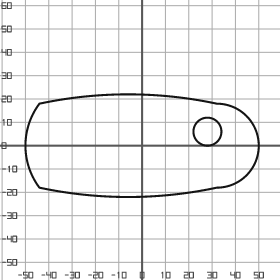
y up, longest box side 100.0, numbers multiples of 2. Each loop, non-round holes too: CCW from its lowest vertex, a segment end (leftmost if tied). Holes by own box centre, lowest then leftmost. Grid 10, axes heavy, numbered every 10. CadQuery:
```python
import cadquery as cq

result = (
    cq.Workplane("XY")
    .moveTo(-44.0, -18.0)
    .threePointArc((-6.0, -22.0), (32.0, -18.0))
    .threePointArc((50.0, 0.0), (32.0, 18.0))
    .threePointArc((-6.0, 22.0), (-44.0, 18.0))
    .threePointArc((-50.0, 0.0), (-44.0, -18.0))
    .close()
    .moveTo(28.0, 6.0)
    .circle(6.0)
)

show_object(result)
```